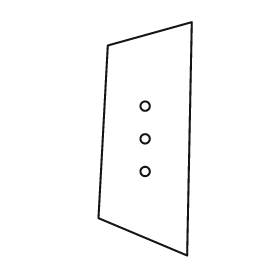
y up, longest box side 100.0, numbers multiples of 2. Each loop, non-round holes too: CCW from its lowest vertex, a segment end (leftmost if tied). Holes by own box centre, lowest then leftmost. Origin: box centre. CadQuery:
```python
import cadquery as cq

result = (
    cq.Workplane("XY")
    .moveTo(18.0, -50.0)
    .lineTo(20.0, 50.0)
    .lineTo(-16.0, 40.0)
    .lineTo(-20.0, -34.0)
    .close()
    .moveTo(0.0, -14.0)
    .circle(2.0)
    .moveTo(0.0, 0.0)
    .circle(2.0)
    .moveTo(0.0, 14.0)
    .circle(2.0)
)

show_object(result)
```